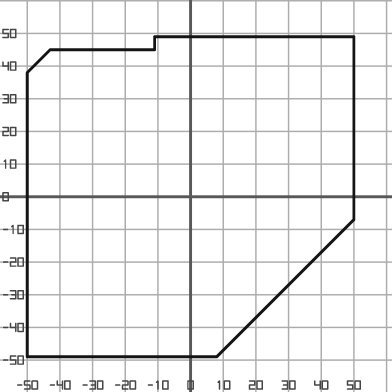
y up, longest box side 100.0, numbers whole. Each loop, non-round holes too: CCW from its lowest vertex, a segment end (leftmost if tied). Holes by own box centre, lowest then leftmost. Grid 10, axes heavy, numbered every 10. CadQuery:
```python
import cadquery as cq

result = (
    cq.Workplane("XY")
    .moveTo(-50.0, -49.0)
    .lineTo(8.0, -49.0)
    .lineTo(50.0, -7.0)
    .lineTo(50.0, 49.0)
    .lineTo(-11.0, 49.0)
    .lineTo(-11.0, 45.0)
    .lineTo(-43.0, 45.0)
    .lineTo(-50.0, 38.0)
    .close()
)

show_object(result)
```